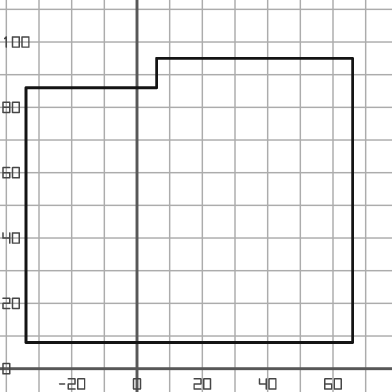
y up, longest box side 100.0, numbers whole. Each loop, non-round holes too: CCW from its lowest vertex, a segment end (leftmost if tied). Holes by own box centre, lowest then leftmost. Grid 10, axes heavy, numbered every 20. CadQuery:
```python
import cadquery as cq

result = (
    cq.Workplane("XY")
    .moveTo(-34.0, 8.0)
    .lineTo(66.0, 8.0)
    .lineTo(66.0, 95.0)
    .lineTo(6.0, 95.0)
    .lineTo(6.0, 86.0)
    .lineTo(-34.0, 86.0)
    .close()
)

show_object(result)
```